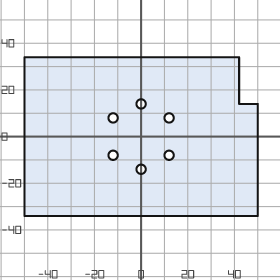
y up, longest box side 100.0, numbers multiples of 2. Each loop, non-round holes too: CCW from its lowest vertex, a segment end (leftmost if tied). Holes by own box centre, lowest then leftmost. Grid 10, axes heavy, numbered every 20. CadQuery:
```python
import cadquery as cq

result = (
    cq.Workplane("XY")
    .moveTo(-50.0, -34.0)
    .lineTo(50.0, -34.0)
    .lineTo(50.0, 14.0)
    .lineTo(42.0, 14.0)
    .lineTo(42.0, 34.0)
    .lineTo(-50.0, 34.0)
    .close()
    .moveTo(0.0, -14.0)
    .circle(2.0)
    .moveTo(-12.0, -8.0)
    .circle(2.0)
    .moveTo(12.0, -8.0)
    .circle(2.0)
    .moveTo(-12.0, 8.0)
    .circle(2.0)
    .moveTo(12.0, 8.0)
    .circle(2.0)
    .moveTo(0.0, 14.0)
    .circle(2.0)
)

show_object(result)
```